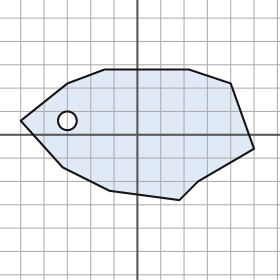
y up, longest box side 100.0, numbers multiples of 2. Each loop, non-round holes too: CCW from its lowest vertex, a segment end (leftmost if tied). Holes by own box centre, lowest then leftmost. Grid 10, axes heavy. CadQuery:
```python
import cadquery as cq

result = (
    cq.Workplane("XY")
    .moveTo(18.0, -28.0)
    .lineTo(26.0, -20.0)
    .lineTo(50.0, -6.0)
    .lineTo(40.0, 22.0)
    .lineTo(22.0, 28.0)
    .lineTo(-14.0, 28.0)
    .lineTo(-30.0, 22.0)
    .lineTo(-50.0, 6.0)
    .lineTo(-32.0, -14.0)
    .lineTo(-12.0, -24.0)
    .close()
    .moveTo(-30.0, 6.0)
    .circle(4.0)
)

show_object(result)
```